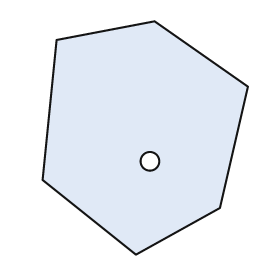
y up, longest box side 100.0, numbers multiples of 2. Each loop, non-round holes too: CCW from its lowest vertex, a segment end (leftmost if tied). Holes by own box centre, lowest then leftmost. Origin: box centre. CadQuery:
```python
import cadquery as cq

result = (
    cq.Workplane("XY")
    .moveTo(-4.0, -50.0)
    .lineTo(32.0, -30.0)
    .lineTo(44.0, 22.0)
    .lineTo(4.0, 50.0)
    .lineTo(-38.0, 42.0)
    .lineTo(-44.0, -18.0)
    .close()
    .moveTo(2.0, -10.0)
    .circle(4.0)
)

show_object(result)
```